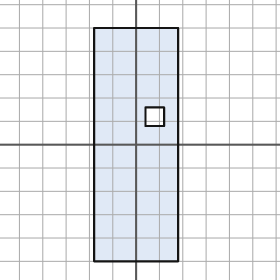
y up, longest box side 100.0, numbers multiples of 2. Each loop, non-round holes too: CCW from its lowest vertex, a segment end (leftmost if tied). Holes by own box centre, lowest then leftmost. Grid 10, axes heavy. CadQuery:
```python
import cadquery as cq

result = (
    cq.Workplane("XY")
    .moveTo(-18.0, -50.0)
    .lineTo(18.0, -50.0)
    .lineTo(18.0, 50.0)
    .lineTo(-18.0, 50.0)
    .close()
    .moveTo(4.0, 8.0)
    .lineTo(12.0, 8.0)
    .lineTo(12.0, 16.0)
    .lineTo(4.0, 16.0)
    .close()
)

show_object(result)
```